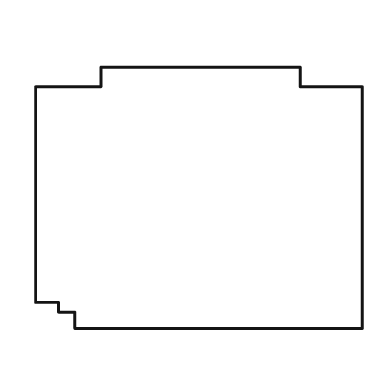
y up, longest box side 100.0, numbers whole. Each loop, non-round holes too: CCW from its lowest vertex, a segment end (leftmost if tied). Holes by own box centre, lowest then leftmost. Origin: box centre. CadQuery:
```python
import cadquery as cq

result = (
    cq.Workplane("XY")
    .moveTo(-38.0, -40.0)
    .lineTo(50.0, -40.0)
    .lineTo(50.0, 34.0)
    .lineTo(31.0, 34.0)
    .lineTo(31.0, 40.0)
    .lineTo(-30.0, 40.0)
    .lineTo(-30.0, 34.0)
    .lineTo(-50.0, 34.0)
    .lineTo(-50.0, -32.0)
    .lineTo(-43.0, -32.0)
    .lineTo(-43.0, -35.0)
    .lineTo(-38.0, -35.0)
    .close()
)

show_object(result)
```